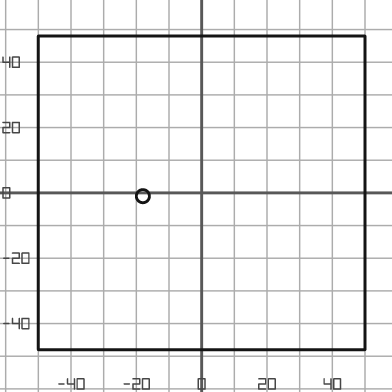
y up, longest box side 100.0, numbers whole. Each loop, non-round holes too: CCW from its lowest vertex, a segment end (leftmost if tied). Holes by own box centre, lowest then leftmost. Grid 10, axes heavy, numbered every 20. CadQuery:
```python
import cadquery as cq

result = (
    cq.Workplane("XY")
    .moveTo(-50.0, -48.0)
    .lineTo(50.0, -48.0)
    .lineTo(50.0, 48.0)
    .lineTo(-50.0, 48.0)
    .close()
    .moveTo(-18.0, -1.0)
    .circle(2.0)
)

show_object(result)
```